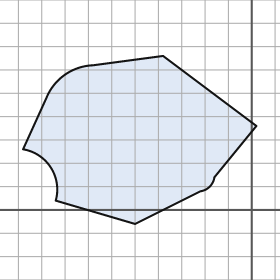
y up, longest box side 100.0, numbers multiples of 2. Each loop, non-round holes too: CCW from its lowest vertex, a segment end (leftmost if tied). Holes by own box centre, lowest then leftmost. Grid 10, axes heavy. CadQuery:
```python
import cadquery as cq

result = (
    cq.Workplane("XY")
    .moveTo(-50.0, -6.0)
    .lineTo(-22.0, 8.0)
    .threePointArc((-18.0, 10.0), (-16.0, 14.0))
    .lineTo(2.0, 36.0)
    .lineTo(-38.0, 66.0)
    .lineTo(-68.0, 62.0)
    .threePointArc((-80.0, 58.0), (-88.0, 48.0))
    .lineTo(-98.0, 26.0)
    .threePointArc((-86.0, 18.0), (-84.0, 4.0))
    .close()
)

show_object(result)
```